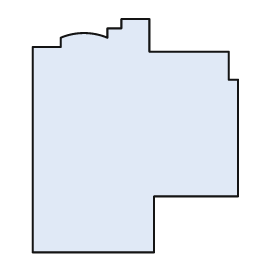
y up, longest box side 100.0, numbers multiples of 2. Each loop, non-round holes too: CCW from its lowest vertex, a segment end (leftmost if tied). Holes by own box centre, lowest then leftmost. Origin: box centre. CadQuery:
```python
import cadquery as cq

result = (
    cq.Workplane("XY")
    .moveTo(-44.0, -50.0)
    .lineTo(8.0, -50.0)
    .lineTo(8.0, -26.0)
    .lineTo(44.0, -26.0)
    .lineTo(44.0, 24.0)
    .lineTo(40.0, 24.0)
    .lineTo(40.0, 36.0)
    .lineTo(6.0, 36.0)
    .lineTo(6.0, 50.0)
    .lineTo(-6.0, 50.0)
    .lineTo(-6.0, 46.0)
    .lineTo(-12.0, 46.0)
    .lineTo(-12.0, 42.0)
    .threePointArc((-22.0, 44.0), (-32.0, 42.0))
    .lineTo(-32.0, 38.0)
    .lineTo(-44.0, 38.0)
    .close()
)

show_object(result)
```